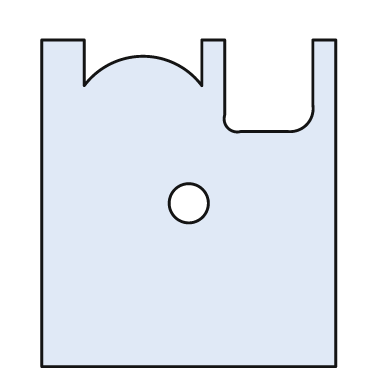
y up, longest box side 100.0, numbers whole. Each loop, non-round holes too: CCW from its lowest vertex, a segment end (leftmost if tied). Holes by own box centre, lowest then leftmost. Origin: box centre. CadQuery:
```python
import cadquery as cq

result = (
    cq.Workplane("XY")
    .moveTo(-45.0, -50.0)
    .lineTo(45.0, -50.0)
    .lineTo(45.0, 50.0)
    .lineTo(38.0, 50.0)
    .lineTo(38.0, 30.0)
    .threePointArc((36.0, 24.0), (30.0, 22.0))
    .lineTo(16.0, 22.0)
    .threePointArc((12.0, 23.0), (11.0, 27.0))
    .lineTo(11.0, 50.0)
    .lineTo(4.0, 50.0)
    .lineTo(4.0, 36.0)
    .threePointArc((-14.0, 45.0), (-32.0, 36.0))
    .lineTo(-32.0, 50.0)
    .lineTo(-45.0, 50.0)
    .close()
    .moveTo(0.0, 0.0)
    .circle(6.0)
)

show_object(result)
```